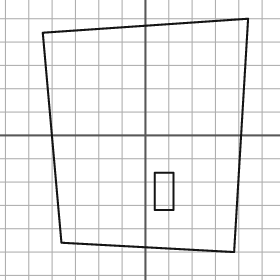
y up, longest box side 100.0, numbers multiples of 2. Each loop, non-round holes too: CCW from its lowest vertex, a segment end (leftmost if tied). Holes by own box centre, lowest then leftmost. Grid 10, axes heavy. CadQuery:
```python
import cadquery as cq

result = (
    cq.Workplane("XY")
    .moveTo(38.0, -50.0)
    .lineTo(44.0, 50.0)
    .lineTo(-44.0, 44.0)
    .lineTo(-36.0, -46.0)
    .close()
    .moveTo(4.0, -32.0)
    .lineTo(12.0, -32.0)
    .lineTo(12.0, -16.0)
    .lineTo(4.0, -16.0)
    .close()
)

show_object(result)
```